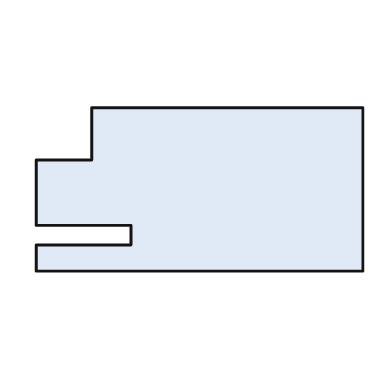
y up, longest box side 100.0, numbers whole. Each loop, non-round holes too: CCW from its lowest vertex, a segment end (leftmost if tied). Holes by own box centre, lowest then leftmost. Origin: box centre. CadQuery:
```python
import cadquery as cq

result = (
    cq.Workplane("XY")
    .moveTo(-50.0, -25.0)
    .lineTo(50.0, -25.0)
    .lineTo(50.0, 25.0)
    .lineTo(-33.0, 25.0)
    .lineTo(-33.0, 9.0)
    .lineTo(-50.0, 9.0)
    .lineTo(-50.0, -11.0)
    .lineTo(-21.0, -11.0)
    .lineTo(-21.0, -17.0)
    .lineTo(-50.0, -17.0)
    .close()
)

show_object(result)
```